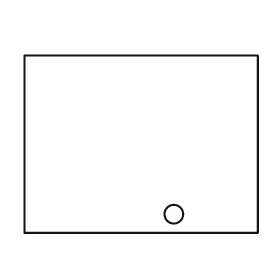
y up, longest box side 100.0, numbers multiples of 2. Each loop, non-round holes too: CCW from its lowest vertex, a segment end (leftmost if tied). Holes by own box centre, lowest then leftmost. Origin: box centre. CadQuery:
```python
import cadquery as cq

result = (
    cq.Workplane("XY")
    .moveTo(-50.0, -38.0)
    .lineTo(50.0, -38.0)
    .lineTo(50.0, 38.0)
    .lineTo(-50.0, 38.0)
    .close()
    .moveTo(14.0, -30.0)
    .circle(4.0)
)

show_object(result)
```